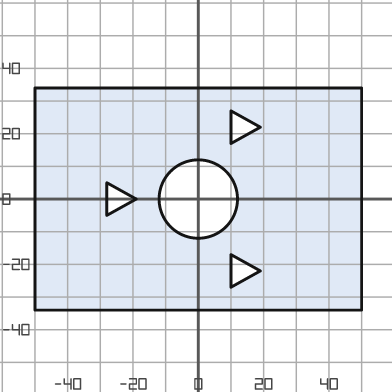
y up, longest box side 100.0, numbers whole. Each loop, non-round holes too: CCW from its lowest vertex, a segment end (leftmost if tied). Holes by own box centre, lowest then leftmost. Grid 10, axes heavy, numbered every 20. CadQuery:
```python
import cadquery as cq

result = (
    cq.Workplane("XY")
    .moveTo(-50.0, -34.0)
    .lineTo(50.0, -34.0)
    .lineTo(50.0, 34.0)
    .lineTo(-50.0, 34.0)
    .close()
    .moveTo(10.0, -27.0)
    .lineTo(19.0, -22.0)
    .lineTo(10.0, -17.0)
    .close()
    .moveTo(-28.0, -5.0)
    .lineTo(-19.0, 0.0)
    .lineTo(-28.0, 5.0)
    .close()
    .moveTo(0.0, 0.0)
    .circle(12.0)
    .moveTo(10.0, 17.0)
    .lineTo(19.0, 22.0)
    .lineTo(10.0, 27.0)
    .close()
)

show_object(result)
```